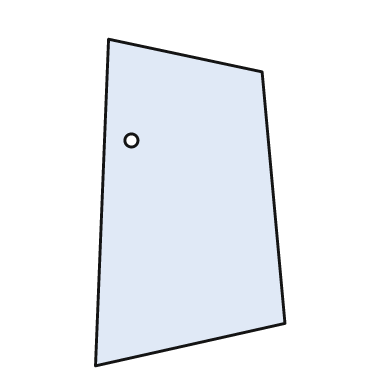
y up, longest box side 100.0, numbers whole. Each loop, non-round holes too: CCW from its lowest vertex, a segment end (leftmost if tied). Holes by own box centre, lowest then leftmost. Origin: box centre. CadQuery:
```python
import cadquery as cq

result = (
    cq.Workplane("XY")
    .moveTo(-29.0, -50.0)
    .lineTo(29.0, -37.0)
    .lineTo(22.0, 40.0)
    .lineTo(-25.0, 50.0)
    .close()
    .moveTo(-18.0, 19.0)
    .circle(2.0)
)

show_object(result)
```